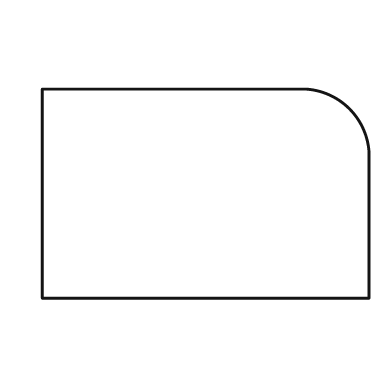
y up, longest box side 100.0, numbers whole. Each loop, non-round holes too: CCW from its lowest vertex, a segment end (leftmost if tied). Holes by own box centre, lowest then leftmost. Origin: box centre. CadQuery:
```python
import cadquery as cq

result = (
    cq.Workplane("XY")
    .moveTo(-50.0, -32.0)
    .lineTo(50.0, -32.0)
    .lineTo(50.0, 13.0)
    .threePointArc((44.0, 26.0), (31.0, 32.0))
    .lineTo(-50.0, 32.0)
    .close()
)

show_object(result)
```